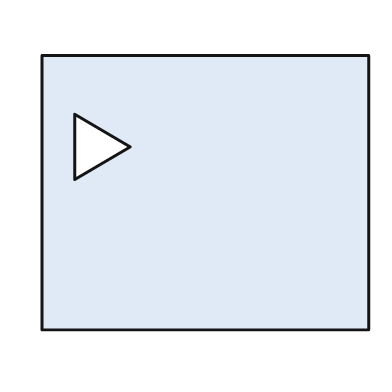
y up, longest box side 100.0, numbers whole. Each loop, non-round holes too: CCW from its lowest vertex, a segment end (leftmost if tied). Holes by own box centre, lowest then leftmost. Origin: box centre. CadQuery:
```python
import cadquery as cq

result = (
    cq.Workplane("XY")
    .moveTo(-50.0, -42.0)
    .lineTo(50.0, -42.0)
    .lineTo(50.0, 42.0)
    .lineTo(-50.0, 42.0)
    .close()
    .moveTo(-40.0, 4.0)
    .lineTo(-23.0, 14.0)
    .lineTo(-40.0, 24.0)
    .close()
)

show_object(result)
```